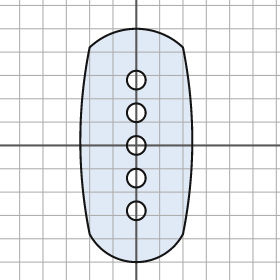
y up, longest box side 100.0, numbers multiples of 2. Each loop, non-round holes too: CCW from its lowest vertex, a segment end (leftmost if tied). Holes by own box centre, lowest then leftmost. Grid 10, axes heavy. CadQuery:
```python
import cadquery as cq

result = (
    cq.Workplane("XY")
    .moveTo(-20.0, -38.0)
    .threePointArc((0.0, -50.0), (20.0, -38.0))
    .threePointArc((24.0, 2.0), (20.0, 42.0))
    .threePointArc((0.0, 50.0), (-20.0, 42.0))
    .threePointArc((-24.0, 2.0), (-20.0, -38.0))
    .close()
    .moveTo(0.0, -28.0)
    .circle(4.0)
    .moveTo(0.0, -14.0)
    .circle(4.0)
    .moveTo(0.0, 0.0)
    .circle(4.0)
    .moveTo(0.0, 14.0)
    .circle(4.0)
    .moveTo(0.0, 28.0)
    .circle(4.0)
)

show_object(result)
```